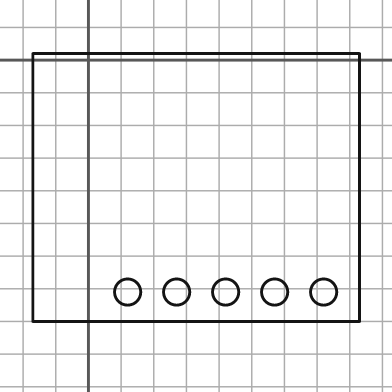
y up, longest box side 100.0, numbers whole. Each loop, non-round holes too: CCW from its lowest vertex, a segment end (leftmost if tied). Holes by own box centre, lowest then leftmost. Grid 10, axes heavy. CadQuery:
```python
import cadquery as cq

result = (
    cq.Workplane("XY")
    .moveTo(-17.0, -80.0)
    .lineTo(83.0, -80.0)
    .lineTo(83.0, 2.0)
    .lineTo(-17.0, 2.0)
    .close()
    .moveTo(12.0, -71.0)
    .circle(4.0)
    .moveTo(27.0, -71.0)
    .circle(4.0)
    .moveTo(42.0, -71.0)
    .circle(4.0)
    .moveTo(57.0, -71.0)
    .circle(4.0)
    .moveTo(72.0, -71.0)
    .circle(4.0)
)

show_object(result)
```